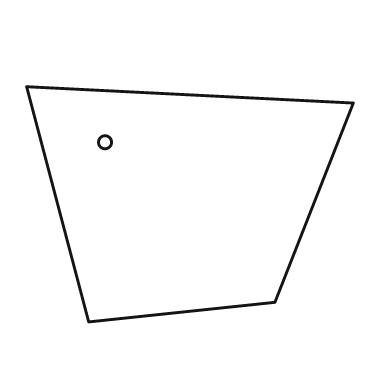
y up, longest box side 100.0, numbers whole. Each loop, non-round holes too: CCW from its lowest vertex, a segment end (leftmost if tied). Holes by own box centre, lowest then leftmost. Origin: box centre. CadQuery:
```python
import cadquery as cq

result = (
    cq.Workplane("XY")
    .moveTo(-31.0, -36.0)
    .lineTo(26.0, -30.0)
    .lineTo(50.0, 31.0)
    .lineTo(-50.0, 36.0)
    .close()
    .moveTo(-26.0, 19.0)
    .circle(2.0)
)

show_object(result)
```